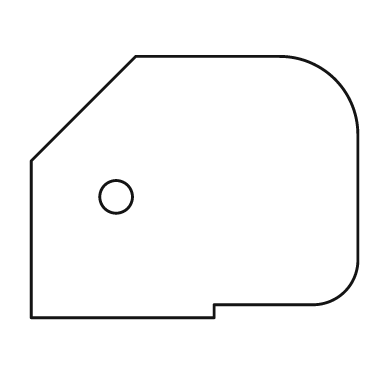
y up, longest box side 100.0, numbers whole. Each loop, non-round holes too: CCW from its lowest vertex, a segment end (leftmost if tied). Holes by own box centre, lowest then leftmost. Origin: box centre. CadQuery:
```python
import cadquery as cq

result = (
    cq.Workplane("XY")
    .moveTo(-50.0, -40.0)
    .lineTo(6.0, -40.0)
    .lineTo(6.0, -36.0)
    .lineTo(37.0, -36.0)
    .threePointArc((46.0, -32.0), (50.0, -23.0))
    .lineTo(50.0, 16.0)
    .threePointArc((43.0, 33.0), (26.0, 40.0))
    .lineTo(-18.0, 40.0)
    .lineTo(-50.0, 8.0)
    .close()
    .moveTo(-24.0, -3.0)
    .circle(5.0)
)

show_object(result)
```